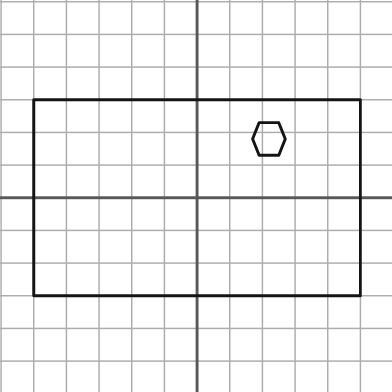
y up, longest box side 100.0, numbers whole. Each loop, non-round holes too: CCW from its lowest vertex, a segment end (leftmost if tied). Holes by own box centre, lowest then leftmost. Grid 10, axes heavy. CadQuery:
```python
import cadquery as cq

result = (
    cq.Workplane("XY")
    .moveTo(-50.0, -30.0)
    .lineTo(50.0, -30.0)
    .lineTo(50.0, 30.0)
    .lineTo(-50.0, 30.0)
    .close()
    .moveTo(19.0, 13.0)
    .lineTo(25.0, 13.0)
    .lineTo(27.0, 18.0)
    .lineTo(25.0, 23.0)
    .lineTo(19.0, 23.0)
    .lineTo(17.0, 18.0)
    .close()
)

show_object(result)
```